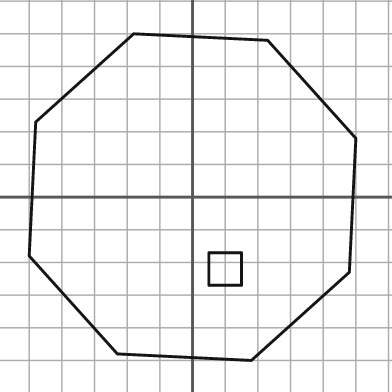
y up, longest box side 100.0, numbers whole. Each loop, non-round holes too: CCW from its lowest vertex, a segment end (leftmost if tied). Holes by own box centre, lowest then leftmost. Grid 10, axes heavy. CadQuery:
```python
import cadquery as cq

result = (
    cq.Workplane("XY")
    .moveTo(18.0, -50.0)
    .lineTo(48.0, -23.0)
    .lineTo(50.0, 18.0)
    .lineTo(23.0, 48.0)
    .lineTo(-18.0, 50.0)
    .lineTo(-48.0, 23.0)
    .lineTo(-50.0, -18.0)
    .lineTo(-23.0, -48.0)
    .close()
    .moveTo(5.0, -27.0)
    .lineTo(15.0, -27.0)
    .lineTo(15.0, -17.0)
    .lineTo(5.0, -17.0)
    .close()
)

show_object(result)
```